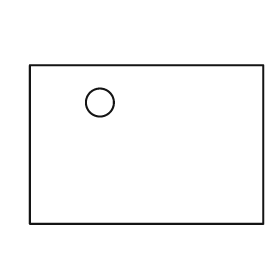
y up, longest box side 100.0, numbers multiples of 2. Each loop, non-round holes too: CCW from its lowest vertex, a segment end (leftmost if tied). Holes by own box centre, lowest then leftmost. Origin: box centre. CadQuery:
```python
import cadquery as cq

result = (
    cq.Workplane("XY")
    .moveTo(-50.0, -34.0)
    .lineTo(50.0, -34.0)
    .lineTo(50.0, 34.0)
    .lineTo(-50.0, 34.0)
    .close()
    .moveTo(-20.0, 18.0)
    .circle(6.0)
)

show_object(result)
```